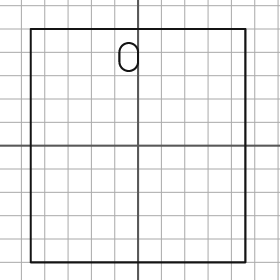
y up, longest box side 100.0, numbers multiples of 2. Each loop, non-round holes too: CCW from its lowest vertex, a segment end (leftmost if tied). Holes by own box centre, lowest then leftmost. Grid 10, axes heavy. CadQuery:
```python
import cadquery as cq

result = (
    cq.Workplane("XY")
    .moveTo(-46.0, -50.0)
    .lineTo(46.0, -50.0)
    .lineTo(46.0, 50.0)
    .lineTo(-46.0, 50.0)
    .close()
    .moveTo(-8.0, 36.0)
    .threePointArc((-4.0, 32.0), (0.0, 36.0))
    .lineTo(0.0, 40.0)
    .threePointArc((-4.0, 44.0), (-8.0, 40.0))
    .close()
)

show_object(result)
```